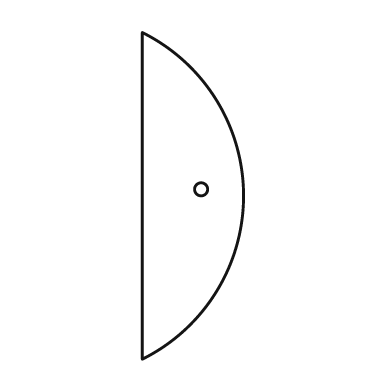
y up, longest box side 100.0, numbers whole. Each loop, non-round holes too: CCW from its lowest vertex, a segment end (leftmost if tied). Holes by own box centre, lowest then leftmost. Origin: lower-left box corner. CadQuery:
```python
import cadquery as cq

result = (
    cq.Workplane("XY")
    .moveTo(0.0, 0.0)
    .threePointArc((31.0, 50.0), (0.0, 100.0))
    .close()
    .moveTo(18.0, 52.0)
    .circle(2.0)
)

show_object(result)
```